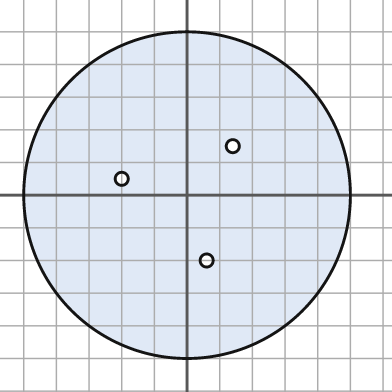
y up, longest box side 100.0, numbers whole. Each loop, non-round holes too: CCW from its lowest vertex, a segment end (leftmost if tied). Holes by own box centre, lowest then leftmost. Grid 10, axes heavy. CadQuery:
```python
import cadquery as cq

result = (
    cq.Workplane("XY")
    .moveTo(0.0, 0.0)
    .circle(50.0)
    .moveTo(6.0, -20.0)
    .circle(2.0)
    .moveTo(-20.0, 5.0)
    .circle(2.0)
    .moveTo(14.0, 15.0)
    .circle(2.0)
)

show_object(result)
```